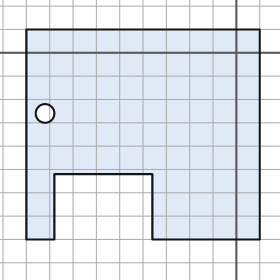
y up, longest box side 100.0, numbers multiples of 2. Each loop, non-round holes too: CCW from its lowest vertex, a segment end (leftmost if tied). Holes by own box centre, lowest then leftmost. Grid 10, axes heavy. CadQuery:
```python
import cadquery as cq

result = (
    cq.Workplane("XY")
    .moveTo(-90.0, -80.0)
    .lineTo(-78.0, -80.0)
    .lineTo(-78.0, -52.0)
    .lineTo(-36.0, -52.0)
    .lineTo(-36.0, -80.0)
    .lineTo(10.0, -80.0)
    .lineTo(10.0, 10.0)
    .lineTo(-90.0, 10.0)
    .close()
    .moveTo(-82.0, -26.0)
    .circle(4.0)
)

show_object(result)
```